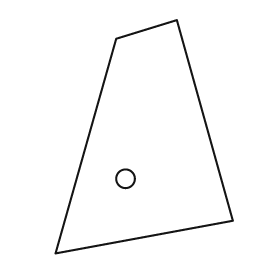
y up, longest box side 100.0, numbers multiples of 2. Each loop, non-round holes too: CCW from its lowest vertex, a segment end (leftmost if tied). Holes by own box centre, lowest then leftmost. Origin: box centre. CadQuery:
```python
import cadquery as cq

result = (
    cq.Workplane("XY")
    .moveTo(-38.0, -50.0)
    .lineTo(38.0, -36.0)
    .lineTo(14.0, 50.0)
    .lineTo(-12.0, 42.0)
    .close()
    .moveTo(-8.0, -18.0)
    .circle(4.0)
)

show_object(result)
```